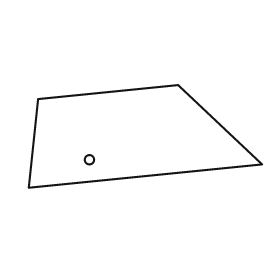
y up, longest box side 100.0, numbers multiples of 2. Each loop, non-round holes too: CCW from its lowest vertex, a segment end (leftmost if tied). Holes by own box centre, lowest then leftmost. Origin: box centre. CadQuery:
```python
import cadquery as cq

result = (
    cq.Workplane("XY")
    .moveTo(-50.0, -22.0)
    .lineTo(50.0, -12.0)
    .lineTo(14.0, 22.0)
    .lineTo(-46.0, 16.0)
    .close()
    .moveTo(-24.0, -10.0)
    .circle(2.0)
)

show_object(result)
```